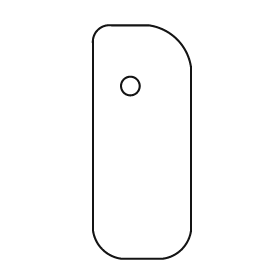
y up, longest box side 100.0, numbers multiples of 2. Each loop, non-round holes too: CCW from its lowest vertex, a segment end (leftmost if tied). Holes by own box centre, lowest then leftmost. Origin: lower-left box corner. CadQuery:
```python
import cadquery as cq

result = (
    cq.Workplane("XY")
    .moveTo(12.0, 0.0)
    .lineTo(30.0, 0.0)
    .threePointArc((38.0, 4.0), (42.0, 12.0))
    .lineTo(42.0, 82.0)
    .threePointArc((36.0, 94.0), (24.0, 100.0))
    .lineTo(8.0, 100.0)
    .threePointArc((2.0, 98.0), (0.0, 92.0))
    .lineTo(0.0, 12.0)
    .threePointArc((4.0, 4.0), (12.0, 0.0))
    .close()
    .moveTo(16.0, 74.0)
    .circle(4.0)
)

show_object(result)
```